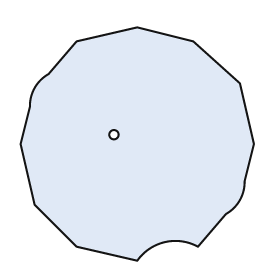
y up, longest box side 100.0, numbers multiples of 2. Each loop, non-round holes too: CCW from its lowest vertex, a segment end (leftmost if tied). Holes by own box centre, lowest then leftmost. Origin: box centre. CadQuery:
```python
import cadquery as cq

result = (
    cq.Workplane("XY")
    .moveTo(0.0, -50.0)
    .threePointArc((12.0, -42.0), (26.0, -44.0))
    .lineTo(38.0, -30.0)
    .threePointArc((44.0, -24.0), (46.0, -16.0))
    .lineTo(50.0, 0.0)
    .lineTo(44.0, 26.0)
    .lineTo(24.0, 44.0)
    .lineTo(0.0, 50.0)
    .lineTo(-26.0, 44.0)
    .lineTo(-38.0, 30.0)
    .threePointArc((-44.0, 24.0), (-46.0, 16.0))
    .lineTo(-50.0, 0.0)
    .lineTo(-44.0, -26.0)
    .lineTo(-26.0, -44.0)
    .close()
    .moveTo(-10.0, 4.0)
    .circle(2.0)
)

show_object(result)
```